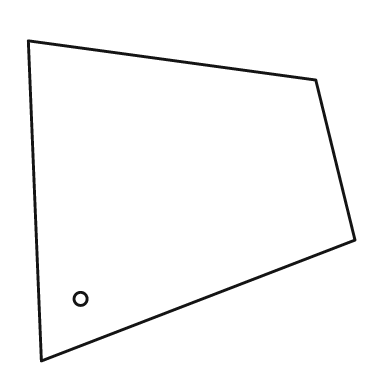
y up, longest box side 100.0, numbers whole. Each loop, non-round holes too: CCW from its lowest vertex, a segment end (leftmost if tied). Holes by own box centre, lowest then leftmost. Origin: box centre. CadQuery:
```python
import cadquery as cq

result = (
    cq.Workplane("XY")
    .moveTo(-46.0, -49.0)
    .lineTo(50.0, -12.0)
    .lineTo(38.0, 37.0)
    .lineTo(-50.0, 49.0)
    .close()
    .moveTo(-34.0, -30.0)
    .circle(2.0)
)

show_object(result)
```